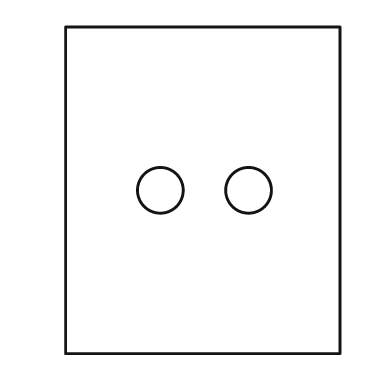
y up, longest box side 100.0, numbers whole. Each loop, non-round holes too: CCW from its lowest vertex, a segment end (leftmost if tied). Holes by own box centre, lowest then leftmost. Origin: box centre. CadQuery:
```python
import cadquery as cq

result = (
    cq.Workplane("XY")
    .moveTo(-42.0, -50.0)
    .lineTo(42.0, -50.0)
    .lineTo(42.0, 50.0)
    .lineTo(-42.0, 50.0)
    .close()
    .moveTo(-13.0, 0.0)
    .circle(7.0)
    .moveTo(14.0, 0.0)
    .circle(7.0)
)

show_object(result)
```